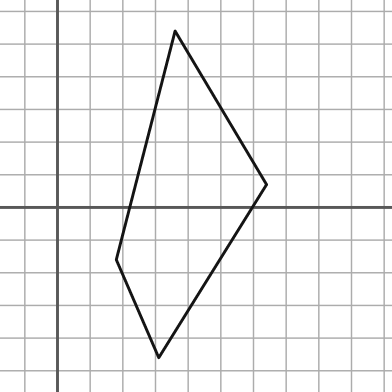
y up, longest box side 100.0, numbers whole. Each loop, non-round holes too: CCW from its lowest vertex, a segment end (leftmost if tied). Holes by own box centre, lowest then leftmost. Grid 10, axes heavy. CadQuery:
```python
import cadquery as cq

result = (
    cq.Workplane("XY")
    .moveTo(31.0, -46.0)
    .lineTo(64.0, 7.0)
    .lineTo(36.0, 54.0)
    .lineTo(18.0, -16.0)
    .close()
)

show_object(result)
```